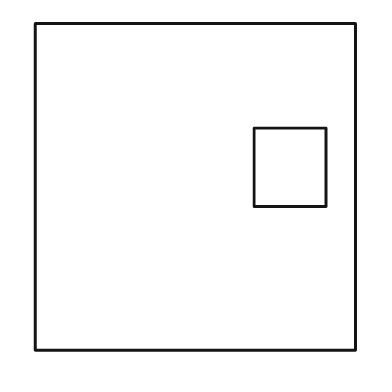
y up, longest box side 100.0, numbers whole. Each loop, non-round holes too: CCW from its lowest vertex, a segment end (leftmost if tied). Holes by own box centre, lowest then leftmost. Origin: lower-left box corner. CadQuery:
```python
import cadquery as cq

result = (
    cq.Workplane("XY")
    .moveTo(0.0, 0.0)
    .lineTo(98.0, 0.0)
    .lineTo(98.0, 100.0)
    .lineTo(0.0, 100.0)
    .close()
    .moveTo(67.0, 44.0)
    .lineTo(89.0, 44.0)
    .lineTo(89.0, 68.0)
    .lineTo(67.0, 68.0)
    .close()
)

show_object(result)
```